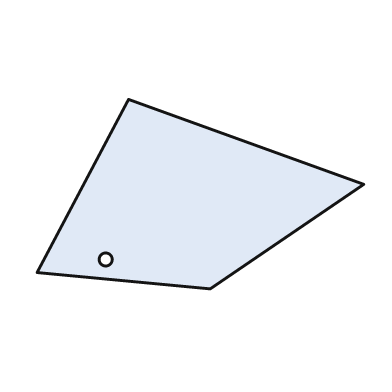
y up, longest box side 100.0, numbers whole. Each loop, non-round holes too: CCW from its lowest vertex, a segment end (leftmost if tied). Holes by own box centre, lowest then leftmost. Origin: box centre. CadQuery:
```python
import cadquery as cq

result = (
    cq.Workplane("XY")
    .moveTo(3.0, -29.0)
    .lineTo(50.0, 3.0)
    .lineTo(-22.0, 29.0)
    .lineTo(-50.0, -24.0)
    .close()
    .moveTo(-29.0, -20.0)
    .circle(2.0)
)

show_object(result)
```